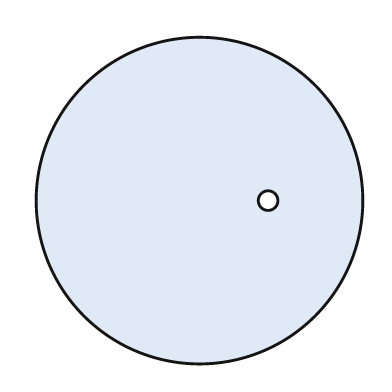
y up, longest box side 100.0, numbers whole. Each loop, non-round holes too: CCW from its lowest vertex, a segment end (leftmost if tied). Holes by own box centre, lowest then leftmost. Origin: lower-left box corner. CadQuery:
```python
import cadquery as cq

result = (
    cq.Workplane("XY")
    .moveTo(50.0, 50.0)
    .circle(50.0)
    .moveTo(71.0, 50.0)
    .circle(3.0)
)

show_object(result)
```